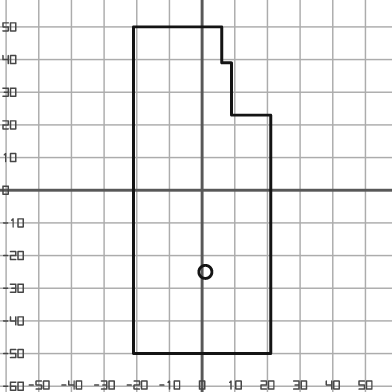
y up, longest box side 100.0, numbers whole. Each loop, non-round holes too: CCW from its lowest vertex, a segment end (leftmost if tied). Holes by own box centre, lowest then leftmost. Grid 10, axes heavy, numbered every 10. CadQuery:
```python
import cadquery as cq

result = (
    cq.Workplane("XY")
    .moveTo(-21.0, -50.0)
    .lineTo(21.0, -50.0)
    .lineTo(21.0, 23.0)
    .lineTo(9.0, 23.0)
    .lineTo(9.0, 39.0)
    .lineTo(6.0, 39.0)
    .lineTo(6.0, 50.0)
    .lineTo(-21.0, 50.0)
    .close()
    .moveTo(1.0, -25.0)
    .circle(2.0)
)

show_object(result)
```